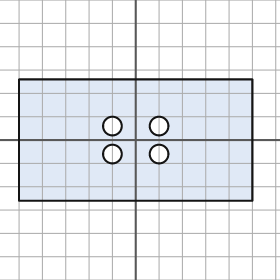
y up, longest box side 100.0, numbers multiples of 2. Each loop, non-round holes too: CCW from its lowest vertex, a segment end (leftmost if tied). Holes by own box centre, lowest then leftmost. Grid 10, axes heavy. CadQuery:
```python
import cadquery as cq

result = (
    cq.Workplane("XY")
    .moveTo(-50.0, -26.0)
    .lineTo(50.0, -26.0)
    .lineTo(50.0, 26.0)
    .lineTo(-50.0, 26.0)
    .close()
    .moveTo(-10.0, -6.0)
    .circle(4.0)
    .moveTo(10.0, -6.0)
    .circle(4.0)
    .moveTo(-10.0, 6.0)
    .circle(4.0)
    .moveTo(10.0, 6.0)
    .circle(4.0)
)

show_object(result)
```